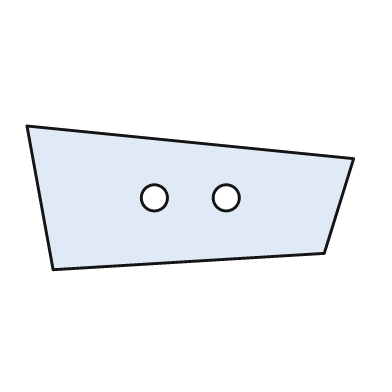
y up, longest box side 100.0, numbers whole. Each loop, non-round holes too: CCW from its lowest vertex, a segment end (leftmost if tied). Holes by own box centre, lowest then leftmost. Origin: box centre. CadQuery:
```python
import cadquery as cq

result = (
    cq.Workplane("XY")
    .moveTo(-42.0, -22.0)
    .lineTo(41.0, -17.0)
    .lineTo(50.0, 12.0)
    .lineTo(-50.0, 22.0)
    .close()
    .moveTo(-11.0, 0.0)
    .circle(4.0)
    .moveTo(11.0, 0.0)
    .circle(4.0)
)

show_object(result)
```